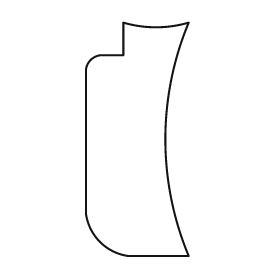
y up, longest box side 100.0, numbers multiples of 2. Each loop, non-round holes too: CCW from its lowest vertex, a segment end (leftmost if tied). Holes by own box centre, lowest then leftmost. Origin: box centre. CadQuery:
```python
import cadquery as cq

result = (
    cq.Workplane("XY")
    .moveTo(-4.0, -50.0)
    .lineTo(22.0, -50.0)
    .threePointArc((12.0, 0.0), (22.0, 50.0))
    .threePointArc((8.0, 48.0), (-6.0, 50.0))
    .lineTo(-6.0, 36.0)
    .lineTo(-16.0, 36.0)
    .threePointArc((-20.0, 34.0), (-22.0, 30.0))
    .lineTo(-22.0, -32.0)
    .threePointArc((-16.0, -44.0), (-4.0, -50.0))
    .close()
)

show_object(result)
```